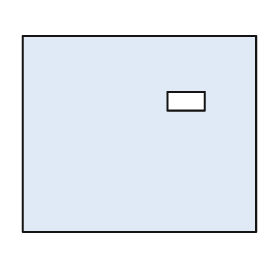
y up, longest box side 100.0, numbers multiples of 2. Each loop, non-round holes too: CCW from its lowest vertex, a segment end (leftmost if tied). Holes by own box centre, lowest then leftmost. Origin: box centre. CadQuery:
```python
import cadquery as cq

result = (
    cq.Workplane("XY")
    .moveTo(-50.0, -42.0)
    .lineTo(50.0, -42.0)
    .lineTo(50.0, 42.0)
    .lineTo(-50.0, 42.0)
    .close()
    .moveTo(12.0, 10.0)
    .lineTo(28.0, 10.0)
    .lineTo(28.0, 18.0)
    .lineTo(12.0, 18.0)
    .close()
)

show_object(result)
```